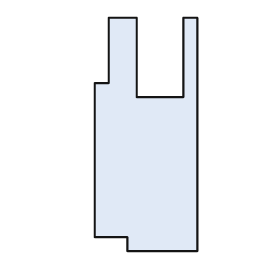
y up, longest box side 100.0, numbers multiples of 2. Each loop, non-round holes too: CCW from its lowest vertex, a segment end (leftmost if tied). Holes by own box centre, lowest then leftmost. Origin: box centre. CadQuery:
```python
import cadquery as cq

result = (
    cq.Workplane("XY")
    .moveTo(-8.0, -50.0)
    .lineTo(22.0, -50.0)
    .lineTo(22.0, 50.0)
    .lineTo(16.0, 50.0)
    .lineTo(16.0, 16.0)
    .lineTo(-4.0, 16.0)
    .lineTo(-4.0, 50.0)
    .lineTo(-16.0, 50.0)
    .lineTo(-16.0, 22.0)
    .lineTo(-22.0, 22.0)
    .lineTo(-22.0, -44.0)
    .lineTo(-8.0, -44.0)
    .close()
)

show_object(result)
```